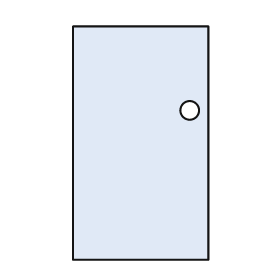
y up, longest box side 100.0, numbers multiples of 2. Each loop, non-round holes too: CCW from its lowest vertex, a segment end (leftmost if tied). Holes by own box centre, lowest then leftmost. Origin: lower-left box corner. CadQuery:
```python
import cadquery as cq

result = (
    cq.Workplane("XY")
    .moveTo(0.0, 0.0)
    .lineTo(58.0, 0.0)
    .lineTo(58.0, 100.0)
    .lineTo(0.0, 100.0)
    .close()
    .moveTo(50.0, 64.0)
    .circle(4.0)
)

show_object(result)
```